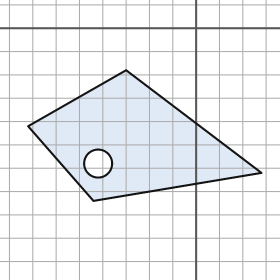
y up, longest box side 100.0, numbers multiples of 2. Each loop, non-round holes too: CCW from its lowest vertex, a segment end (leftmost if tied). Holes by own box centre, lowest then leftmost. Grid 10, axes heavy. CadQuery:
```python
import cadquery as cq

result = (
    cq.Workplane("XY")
    .moveTo(-44.0, -74.0)
    .lineTo(28.0, -62.0)
    .lineTo(-30.0, -18.0)
    .lineTo(-72.0, -42.0)
    .close()
    .moveTo(-42.0, -58.0)
    .circle(6.0)
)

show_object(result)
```